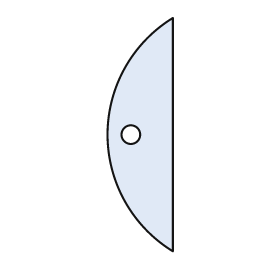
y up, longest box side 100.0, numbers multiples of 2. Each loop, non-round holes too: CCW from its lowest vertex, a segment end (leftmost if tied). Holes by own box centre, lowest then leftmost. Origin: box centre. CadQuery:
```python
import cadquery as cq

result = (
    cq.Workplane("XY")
    .moveTo(14.0, -50.0)
    .lineTo(14.0, 50.0)
    .threePointArc((-14.0, 0.0), (14.0, -50.0))
    .close()
    .moveTo(-4.0, 0.0)
    .circle(4.0)
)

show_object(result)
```